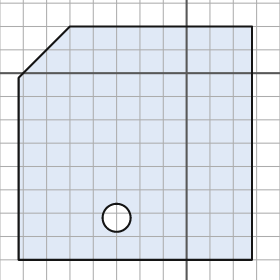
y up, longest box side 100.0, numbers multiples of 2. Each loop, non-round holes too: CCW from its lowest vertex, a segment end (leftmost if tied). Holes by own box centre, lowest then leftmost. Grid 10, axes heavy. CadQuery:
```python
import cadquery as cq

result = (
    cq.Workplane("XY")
    .moveTo(-72.0, -80.0)
    .lineTo(28.0, -80.0)
    .lineTo(28.0, 20.0)
    .lineTo(-50.0, 20.0)
    .lineTo(-72.0, -2.0)
    .close()
    .moveTo(-30.0, -62.0)
    .circle(6.0)
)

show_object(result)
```